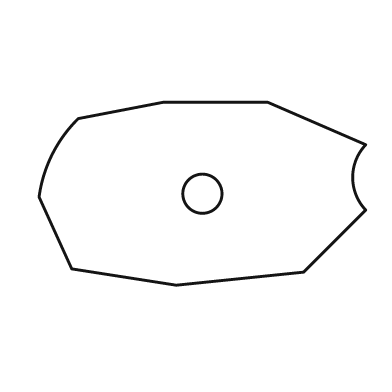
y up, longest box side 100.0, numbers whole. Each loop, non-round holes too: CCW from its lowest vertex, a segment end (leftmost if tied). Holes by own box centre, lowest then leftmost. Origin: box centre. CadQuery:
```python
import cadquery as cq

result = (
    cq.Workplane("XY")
    .moveTo(-8.0, -28.0)
    .lineTo(31.0, -24.0)
    .lineTo(50.0, -5.0)
    .threePointArc((46.0, 5.0), (50.0, 15.0))
    .lineTo(20.0, 28.0)
    .lineTo(-12.0, 28.0)
    .lineTo(-38.0, 23.0)
    .threePointArc((-46.0, 12.0), (-50.0, -1.0))
    .lineTo(-40.0, -23.0)
    .close()
    .moveTo(0.0, 0.0)
    .circle(6.0)
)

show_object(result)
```